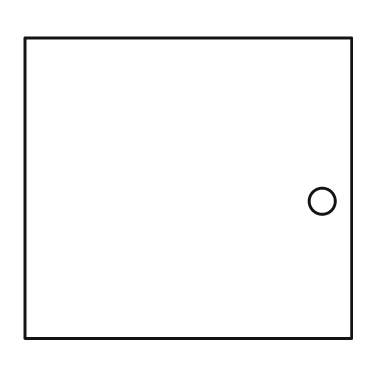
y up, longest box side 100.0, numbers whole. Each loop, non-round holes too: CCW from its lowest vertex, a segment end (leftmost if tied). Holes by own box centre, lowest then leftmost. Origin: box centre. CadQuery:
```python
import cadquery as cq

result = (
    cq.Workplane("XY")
    .moveTo(-50.0, -46.0)
    .lineTo(50.0, -46.0)
    .lineTo(50.0, 46.0)
    .lineTo(-50.0, 46.0)
    .close()
    .moveTo(41.0, -4.0)
    .circle(4.0)
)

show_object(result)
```